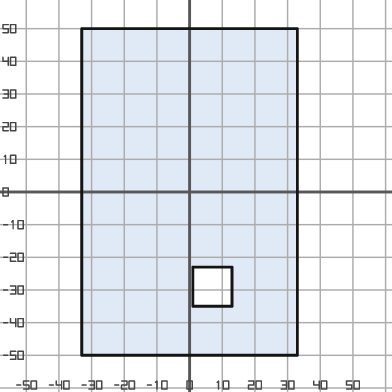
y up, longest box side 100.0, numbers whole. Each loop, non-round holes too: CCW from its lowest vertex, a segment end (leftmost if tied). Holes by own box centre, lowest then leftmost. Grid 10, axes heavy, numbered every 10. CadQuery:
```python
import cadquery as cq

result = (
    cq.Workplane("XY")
    .moveTo(-33.0, -50.0)
    .lineTo(33.0, -50.0)
    .lineTo(33.0, 50.0)
    .lineTo(-33.0, 50.0)
    .close()
    .moveTo(1.0, -35.0)
    .lineTo(13.0, -35.0)
    .lineTo(13.0, -23.0)
    .lineTo(1.0, -23.0)
    .close()
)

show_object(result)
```